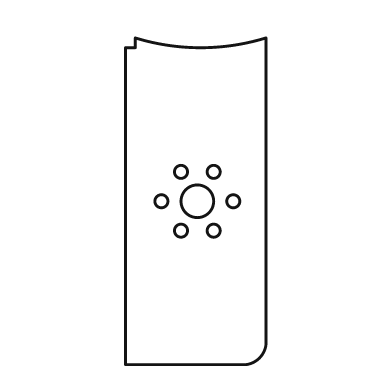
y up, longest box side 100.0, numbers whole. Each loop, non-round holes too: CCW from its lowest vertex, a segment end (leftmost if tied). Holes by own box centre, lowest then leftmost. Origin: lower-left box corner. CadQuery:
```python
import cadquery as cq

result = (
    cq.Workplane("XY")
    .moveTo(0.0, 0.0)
    .lineTo(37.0, 0.0)
    .threePointArc((41.0, 2.0), (43.0, 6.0))
    .lineTo(43.0, 100.0)
    .threePointArc((23.0, 97.0), (3.0, 100.0))
    .lineTo(3.0, 97.0)
    .lineTo(0.0, 97.0)
    .close()
    .moveTo(17.0, 41.0)
    .circle(2.0)
    .moveTo(27.0, 41.0)
    .circle(2.0)
    .moveTo(11.0, 50.0)
    .circle(2.0)
    .moveTo(22.0, 50.0)
    .circle(5.0)
    .moveTo(33.0, 50.0)
    .circle(2.0)
    .moveTo(17.0, 59.0)
    .circle(2.0)
    .moveTo(27.0, 59.0)
    .circle(2.0)
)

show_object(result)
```